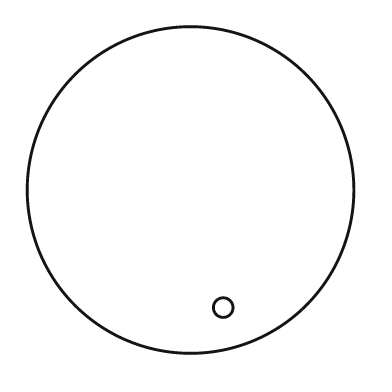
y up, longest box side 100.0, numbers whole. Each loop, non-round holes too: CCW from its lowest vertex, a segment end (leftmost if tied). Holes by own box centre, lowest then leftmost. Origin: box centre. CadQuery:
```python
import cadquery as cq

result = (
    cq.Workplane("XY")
    .moveTo(0.0, 0.0)
    .circle(50.0)
    .moveTo(10.0, -36.0)
    .circle(3.0)
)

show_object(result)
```